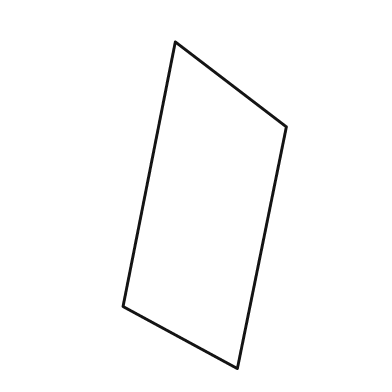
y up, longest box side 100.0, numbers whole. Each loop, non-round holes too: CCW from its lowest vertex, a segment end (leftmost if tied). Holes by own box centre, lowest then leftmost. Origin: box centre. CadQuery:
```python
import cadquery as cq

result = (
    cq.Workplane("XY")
    .moveTo(10.0, -50.0)
    .lineTo(25.0, 24.0)
    .lineTo(-9.0, 50.0)
    .lineTo(-25.0, -31.0)
    .close()
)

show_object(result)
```